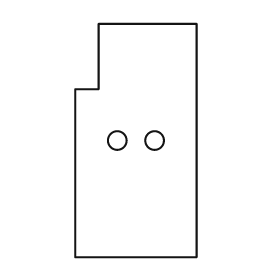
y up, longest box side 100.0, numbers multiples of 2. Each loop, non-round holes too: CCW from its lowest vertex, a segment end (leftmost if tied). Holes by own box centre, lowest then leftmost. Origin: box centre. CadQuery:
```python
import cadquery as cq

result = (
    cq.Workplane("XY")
    .moveTo(-26.0, -50.0)
    .lineTo(26.0, -50.0)
    .lineTo(26.0, 50.0)
    .lineTo(-16.0, 50.0)
    .lineTo(-16.0, 22.0)
    .lineTo(-26.0, 22.0)
    .close()
    .moveTo(-8.0, 0.0)
    .circle(4.0)
    .moveTo(8.0, 0.0)
    .circle(4.0)
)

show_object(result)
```